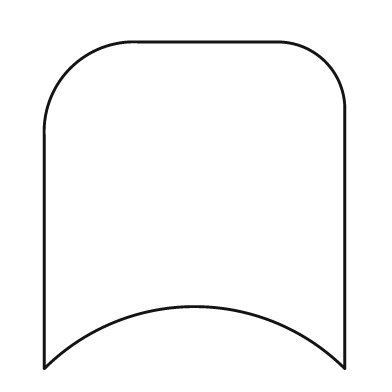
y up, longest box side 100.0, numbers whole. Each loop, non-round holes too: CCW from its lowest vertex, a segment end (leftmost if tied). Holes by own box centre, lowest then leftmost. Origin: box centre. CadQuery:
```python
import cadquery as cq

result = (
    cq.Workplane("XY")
    .moveTo(-46.0, -50.0)
    .threePointArc((0.0, -31.0), (46.0, -50.0))
    .lineTo(46.0, 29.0)
    .threePointArc((40.0, 44.0), (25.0, 50.0))
    .lineTo(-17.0, 50.0)
    .threePointArc((-38.0, 42.0), (-46.0, 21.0))
    .close()
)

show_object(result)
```